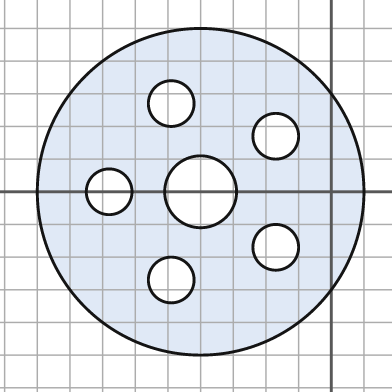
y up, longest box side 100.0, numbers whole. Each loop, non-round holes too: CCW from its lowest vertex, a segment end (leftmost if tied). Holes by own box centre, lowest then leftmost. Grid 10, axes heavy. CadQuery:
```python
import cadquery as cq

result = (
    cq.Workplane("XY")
    .moveTo(-40.0, 0.0)
    .circle(50.0)
    .moveTo(-49.0, -27.0)
    .circle(7.0)
    .moveTo(-17.0, -17.0)
    .circle(7.0)
    .moveTo(-68.0, 0.0)
    .circle(7.0)
    .moveTo(-40.0, 0.0)
    .circle(11.0)
    .moveTo(-17.0, 17.0)
    .circle(7.0)
    .moveTo(-49.0, 27.0)
    .circle(7.0)
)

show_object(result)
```